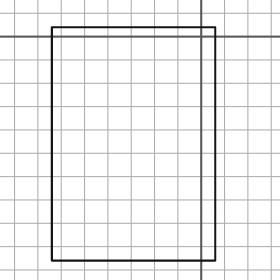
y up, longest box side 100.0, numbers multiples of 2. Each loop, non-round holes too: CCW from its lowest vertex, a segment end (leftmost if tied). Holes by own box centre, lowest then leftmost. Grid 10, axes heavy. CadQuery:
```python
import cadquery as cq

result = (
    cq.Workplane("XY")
    .moveTo(-64.0, -96.0)
    .lineTo(6.0, -96.0)
    .lineTo(6.0, 4.0)
    .lineTo(-64.0, 4.0)
    .close()
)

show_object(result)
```